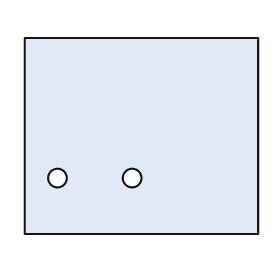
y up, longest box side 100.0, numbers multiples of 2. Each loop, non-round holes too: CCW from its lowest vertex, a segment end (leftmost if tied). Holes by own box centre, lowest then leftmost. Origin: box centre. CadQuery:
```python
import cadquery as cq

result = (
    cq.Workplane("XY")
    .moveTo(-50.0, -42.0)
    .lineTo(50.0, -42.0)
    .lineTo(50.0, 42.0)
    .lineTo(-50.0, 42.0)
    .close()
    .moveTo(-36.0, -18.0)
    .circle(4.0)
    .moveTo(-4.0, -18.0)
    .circle(4.0)
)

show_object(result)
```